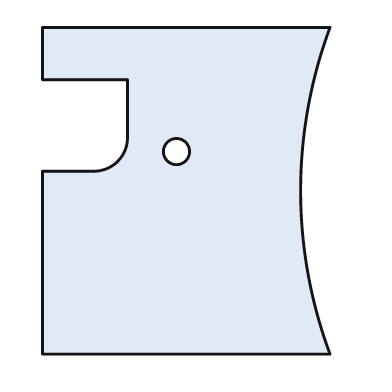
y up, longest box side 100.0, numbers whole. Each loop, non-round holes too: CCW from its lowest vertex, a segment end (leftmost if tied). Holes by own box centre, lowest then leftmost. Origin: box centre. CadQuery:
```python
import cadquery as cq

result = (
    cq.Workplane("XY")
    .moveTo(-44.0, -50.0)
    .lineTo(44.0, -50.0)
    .threePointArc((35.0, 0.0), (44.0, 50.0))
    .lineTo(-44.0, 50.0)
    .lineTo(-44.0, 34.0)
    .lineTo(-18.0, 34.0)
    .lineTo(-18.0, 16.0)
    .threePointArc((-21.0, 9.0), (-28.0, 6.0))
    .lineTo(-44.0, 6.0)
    .close()
    .moveTo(-3.0, 12.0)
    .circle(4.0)
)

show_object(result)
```